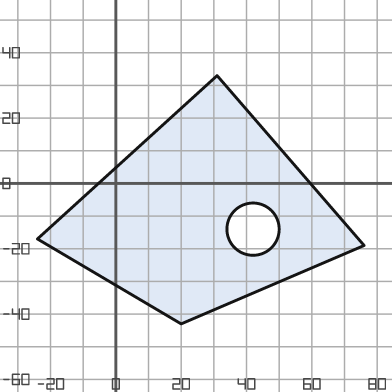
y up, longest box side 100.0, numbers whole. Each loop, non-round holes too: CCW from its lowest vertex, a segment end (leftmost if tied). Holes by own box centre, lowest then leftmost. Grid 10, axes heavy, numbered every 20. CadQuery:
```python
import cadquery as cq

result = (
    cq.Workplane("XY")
    .moveTo(20.0, -43.0)
    .lineTo(76.0, -19.0)
    .lineTo(31.0, 33.0)
    .lineTo(-24.0, -17.0)
    .close()
    .moveTo(42.0, -14.0)
    .circle(8.0)
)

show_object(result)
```